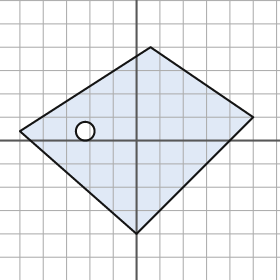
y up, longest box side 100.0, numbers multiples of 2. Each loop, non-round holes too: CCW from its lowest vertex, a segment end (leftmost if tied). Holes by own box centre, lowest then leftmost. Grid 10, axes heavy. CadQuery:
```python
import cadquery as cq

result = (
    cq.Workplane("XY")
    .moveTo(0.0, -40.0)
    .lineTo(50.0, 10.0)
    .lineTo(6.0, 40.0)
    .lineTo(-50.0, 4.0)
    .close()
    .moveTo(-22.0, 4.0)
    .circle(4.0)
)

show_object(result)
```